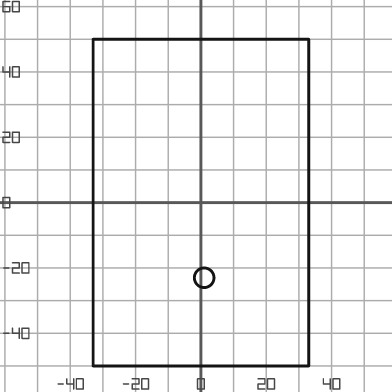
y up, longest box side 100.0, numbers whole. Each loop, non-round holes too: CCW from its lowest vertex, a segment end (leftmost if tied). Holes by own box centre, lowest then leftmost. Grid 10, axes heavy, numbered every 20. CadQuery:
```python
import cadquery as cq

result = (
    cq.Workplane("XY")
    .moveTo(-33.0, -50.0)
    .lineTo(33.0, -50.0)
    .lineTo(33.0, 50.0)
    .lineTo(-33.0, 50.0)
    .close()
    .moveTo(1.0, -23.0)
    .circle(3.0)
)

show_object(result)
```